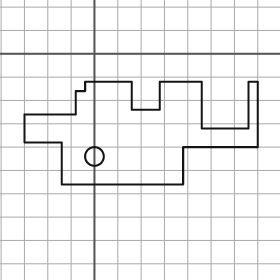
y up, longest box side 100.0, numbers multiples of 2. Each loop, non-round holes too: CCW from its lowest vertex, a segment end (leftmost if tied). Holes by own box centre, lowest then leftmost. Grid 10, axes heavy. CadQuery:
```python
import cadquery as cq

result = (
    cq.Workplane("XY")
    .moveTo(-14.0, -56.0)
    .lineTo(38.0, -56.0)
    .lineTo(38.0, -40.0)
    .lineTo(70.0, -40.0)
    .lineTo(70.0, -12.0)
    .lineTo(66.0, -12.0)
    .lineTo(66.0, -32.0)
    .lineTo(46.0, -32.0)
    .lineTo(46.0, -12.0)
    .lineTo(28.0, -12.0)
    .lineTo(28.0, -24.0)
    .lineTo(16.0, -24.0)
    .lineTo(16.0, -12.0)
    .lineTo(-4.0, -12.0)
    .lineTo(-4.0, -16.0)
    .lineTo(-8.0, -16.0)
    .lineTo(-8.0, -26.0)
    .lineTo(-30.0, -26.0)
    .lineTo(-30.0, -38.0)
    .lineTo(-14.0, -38.0)
    .close()
    .moveTo(0.0, -44.0)
    .circle(4.0)
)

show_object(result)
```